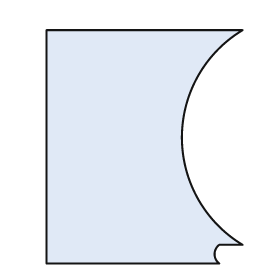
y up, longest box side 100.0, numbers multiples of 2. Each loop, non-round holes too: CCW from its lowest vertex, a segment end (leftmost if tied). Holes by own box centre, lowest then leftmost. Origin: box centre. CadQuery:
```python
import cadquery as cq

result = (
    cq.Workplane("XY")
    .moveTo(-42.0, -50.0)
    .lineTo(32.0, -50.0)
    .threePointArc((30.0, -46.0), (32.0, -42.0))
    .lineTo(42.0, -42.0)
    .threePointArc((16.0, 4.0), (42.0, 50.0))
    .lineTo(-42.0, 50.0)
    .close()
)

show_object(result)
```